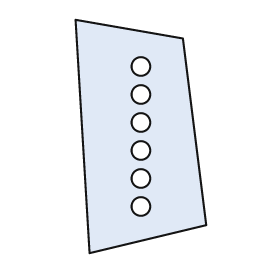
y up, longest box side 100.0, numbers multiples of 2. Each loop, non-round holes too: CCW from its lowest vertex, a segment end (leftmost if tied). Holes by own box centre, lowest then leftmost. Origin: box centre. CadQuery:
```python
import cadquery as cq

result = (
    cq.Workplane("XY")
    .moveTo(-22.0, -50.0)
    .lineTo(28.0, -38.0)
    .lineTo(18.0, 42.0)
    .lineTo(-28.0, 50.0)
    .close()
    .moveTo(0.0, -30.0)
    .circle(4.0)
    .moveTo(0.0, -18.0)
    .circle(4.0)
    .moveTo(0.0, -6.0)
    .circle(4.0)
    .moveTo(0.0, 6.0)
    .circle(4.0)
    .moveTo(0.0, 18.0)
    .circle(4.0)
    .moveTo(0.0, 30.0)
    .circle(4.0)
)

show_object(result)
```